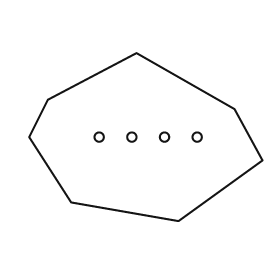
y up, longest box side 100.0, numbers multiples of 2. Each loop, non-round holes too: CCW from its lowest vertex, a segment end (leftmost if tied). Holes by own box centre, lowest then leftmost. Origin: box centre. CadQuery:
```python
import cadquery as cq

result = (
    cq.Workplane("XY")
    .moveTo(14.0, -36.0)
    .lineTo(50.0, -10.0)
    .lineTo(38.0, 12.0)
    .lineTo(-4.0, 36.0)
    .lineTo(-42.0, 16.0)
    .lineTo(-50.0, 0.0)
    .lineTo(-32.0, -28.0)
    .close()
    .moveTo(-20.0, 0.0)
    .circle(2.0)
    .moveTo(-6.0, 0.0)
    .circle(2.0)
    .moveTo(8.0, 0.0)
    .circle(2.0)
    .moveTo(22.0, 0.0)
    .circle(2.0)
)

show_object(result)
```